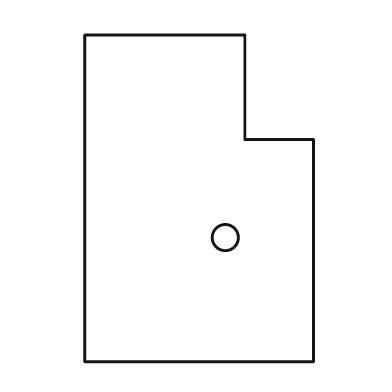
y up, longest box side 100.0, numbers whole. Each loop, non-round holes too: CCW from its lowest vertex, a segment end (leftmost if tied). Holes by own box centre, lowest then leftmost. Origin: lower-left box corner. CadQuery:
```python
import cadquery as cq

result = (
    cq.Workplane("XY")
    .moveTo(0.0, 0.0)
    .lineTo(70.0, 0.0)
    .lineTo(70.0, 68.0)
    .lineTo(49.0, 68.0)
    .lineTo(49.0, 100.0)
    .lineTo(0.0, 100.0)
    .close()
    .moveTo(43.0, 38.0)
    .circle(4.0)
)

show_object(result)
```